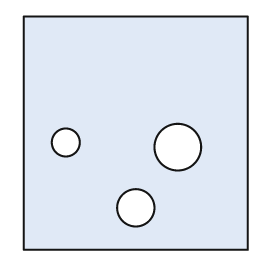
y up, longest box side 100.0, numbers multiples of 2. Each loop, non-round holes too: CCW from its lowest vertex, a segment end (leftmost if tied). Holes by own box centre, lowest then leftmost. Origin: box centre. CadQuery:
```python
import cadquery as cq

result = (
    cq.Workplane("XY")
    .moveTo(-48.0, -50.0)
    .lineTo(48.0, -50.0)
    .lineTo(48.0, 50.0)
    .lineTo(-48.0, 50.0)
    .close()
    .moveTo(0.0, -32.0)
    .circle(8.0)
    .moveTo(18.0, -6.0)
    .circle(10.0)
    .moveTo(-30.0, -4.0)
    .circle(6.0)
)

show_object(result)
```